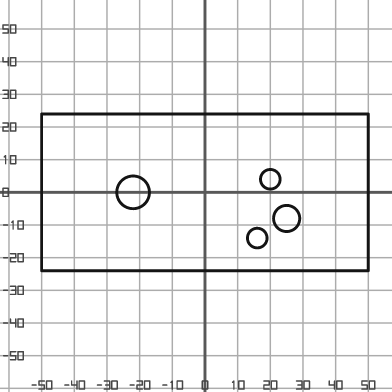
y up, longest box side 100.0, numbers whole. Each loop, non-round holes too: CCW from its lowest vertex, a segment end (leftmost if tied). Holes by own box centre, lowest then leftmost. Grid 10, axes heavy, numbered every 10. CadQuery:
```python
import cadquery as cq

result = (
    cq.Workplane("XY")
    .moveTo(-50.0, -24.0)
    .lineTo(50.0, -24.0)
    .lineTo(50.0, 24.0)
    .lineTo(-50.0, 24.0)
    .close()
    .moveTo(16.0, -14.0)
    .circle(3.0)
    .moveTo(25.0, -8.0)
    .circle(4.0)
    .moveTo(-22.0, 0.0)
    .circle(5.0)
    .moveTo(20.0, 4.0)
    .circle(3.0)
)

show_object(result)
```